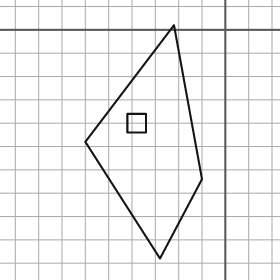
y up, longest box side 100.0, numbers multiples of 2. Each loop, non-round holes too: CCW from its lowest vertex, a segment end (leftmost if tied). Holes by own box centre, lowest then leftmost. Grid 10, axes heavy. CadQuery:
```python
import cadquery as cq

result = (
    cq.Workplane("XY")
    .moveTo(-28.0, -98.0)
    .lineTo(-10.0, -64.0)
    .lineTo(-22.0, 2.0)
    .lineTo(-60.0, -48.0)
    .close()
    .moveTo(-42.0, -44.0)
    .lineTo(-34.0, -44.0)
    .lineTo(-34.0, -36.0)
    .lineTo(-42.0, -36.0)
    .close()
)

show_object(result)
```